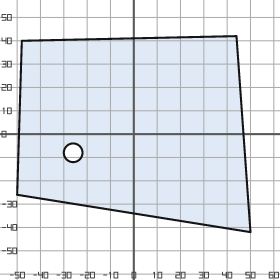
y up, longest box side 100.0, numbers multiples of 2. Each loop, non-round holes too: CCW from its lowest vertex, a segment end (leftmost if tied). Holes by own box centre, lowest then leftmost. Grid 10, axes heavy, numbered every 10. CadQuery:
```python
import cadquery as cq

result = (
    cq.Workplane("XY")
    .moveTo(50.0, -42.0)
    .lineTo(44.0, 42.0)
    .lineTo(-48.0, 40.0)
    .lineTo(-50.0, -26.0)
    .close()
    .moveTo(-26.0, -8.0)
    .circle(4.0)
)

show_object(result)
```